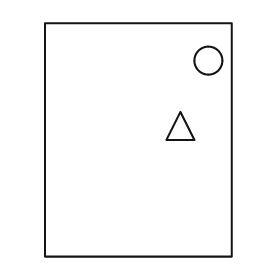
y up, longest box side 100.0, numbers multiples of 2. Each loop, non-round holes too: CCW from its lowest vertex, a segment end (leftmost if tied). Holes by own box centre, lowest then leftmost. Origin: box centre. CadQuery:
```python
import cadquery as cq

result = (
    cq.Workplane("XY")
    .moveTo(-40.0, -50.0)
    .lineTo(40.0, -50.0)
    .lineTo(40.0, 50.0)
    .lineTo(-40.0, 50.0)
    .close()
    .moveTo(12.0, 0.0)
    .lineTo(24.0, 0.0)
    .lineTo(18.0, 12.0)
    .close()
    .moveTo(30.0, 34.0)
    .circle(6.0)
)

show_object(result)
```